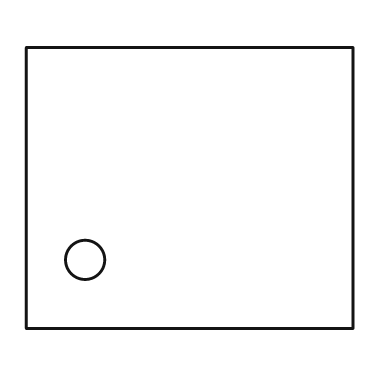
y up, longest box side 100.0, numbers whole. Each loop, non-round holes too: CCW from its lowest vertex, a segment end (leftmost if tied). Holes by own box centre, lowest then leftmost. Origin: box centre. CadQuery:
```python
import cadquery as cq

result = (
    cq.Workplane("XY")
    .moveTo(-50.0, -43.0)
    .lineTo(50.0, -43.0)
    .lineTo(50.0, 43.0)
    .lineTo(-50.0, 43.0)
    .close()
    .moveTo(-32.0, -22.0)
    .circle(6.0)
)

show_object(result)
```